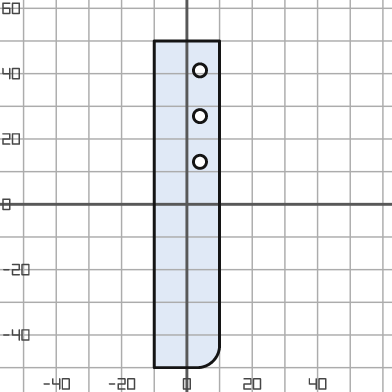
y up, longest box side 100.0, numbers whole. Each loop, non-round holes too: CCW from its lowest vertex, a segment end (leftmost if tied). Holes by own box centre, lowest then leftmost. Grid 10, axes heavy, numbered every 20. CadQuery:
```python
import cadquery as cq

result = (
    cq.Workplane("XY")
    .moveTo(-10.0, -50.0)
    .lineTo(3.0, -50.0)
    .threePointArc((8.0, -48.0), (10.0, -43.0))
    .lineTo(10.0, 50.0)
    .lineTo(-10.0, 50.0)
    .close()
    .moveTo(4.0, 13.0)
    .circle(2.0)
    .moveTo(4.0, 27.0)
    .circle(2.0)
    .moveTo(4.0, 41.0)
    .circle(2.0)
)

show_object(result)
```